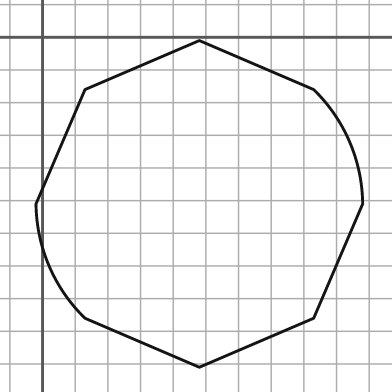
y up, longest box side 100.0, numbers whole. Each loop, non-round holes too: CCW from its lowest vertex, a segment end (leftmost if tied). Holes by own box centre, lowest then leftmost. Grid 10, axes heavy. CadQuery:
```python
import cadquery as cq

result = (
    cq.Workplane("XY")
    .moveTo(48.0, -101.0)
    .lineTo(83.0, -86.0)
    .lineTo(98.0, -51.0)
    .threePointArc((94.0, -32.0), (83.0, -16.0))
    .lineTo(48.0, -1.0)
    .lineTo(13.0, -16.0)
    .lineTo(-2.0, -51.0)
    .threePointArc((2.0, -70.0), (13.0, -86.0))
    .close()
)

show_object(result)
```